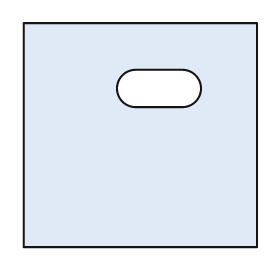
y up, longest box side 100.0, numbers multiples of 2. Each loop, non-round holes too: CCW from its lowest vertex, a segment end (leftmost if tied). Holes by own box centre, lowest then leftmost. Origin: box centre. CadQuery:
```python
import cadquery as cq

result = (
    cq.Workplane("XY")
    .moveTo(-50.0, -48.0)
    .lineTo(50.0, -48.0)
    .lineTo(50.0, 48.0)
    .lineTo(-50.0, 48.0)
    .close()
    .moveTo(-2.0, 12.0)
    .lineTo(18.0, 12.0)
    .threePointArc((26.0, 20.0), (18.0, 28.0))
    .lineTo(-2.0, 28.0)
    .threePointArc((-10.0, 20.0), (-2.0, 12.0))
    .close()
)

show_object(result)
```